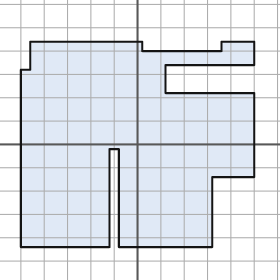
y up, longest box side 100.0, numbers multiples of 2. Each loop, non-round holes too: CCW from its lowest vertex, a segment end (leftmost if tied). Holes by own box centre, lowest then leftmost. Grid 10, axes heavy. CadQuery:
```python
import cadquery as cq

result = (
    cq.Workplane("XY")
    .moveTo(-50.0, -44.0)
    .lineTo(-12.0, -44.0)
    .lineTo(-12.0, -2.0)
    .lineTo(-8.0, -2.0)
    .lineTo(-8.0, -44.0)
    .lineTo(32.0, -44.0)
    .lineTo(32.0, -14.0)
    .lineTo(50.0, -14.0)
    .lineTo(50.0, 22.0)
    .lineTo(12.0, 22.0)
    .lineTo(12.0, 34.0)
    .lineTo(50.0, 34.0)
    .lineTo(50.0, 44.0)
    .lineTo(36.0, 44.0)
    .lineTo(36.0, 40.0)
    .lineTo(2.0, 40.0)
    .lineTo(2.0, 44.0)
    .lineTo(-46.0, 44.0)
    .lineTo(-46.0, 32.0)
    .lineTo(-50.0, 32.0)
    .close()
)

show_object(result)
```